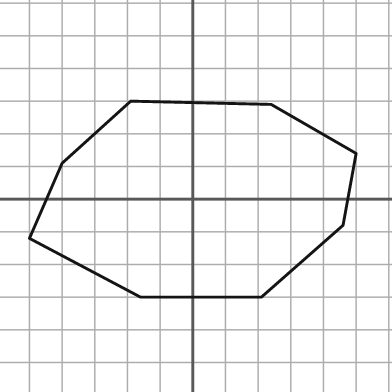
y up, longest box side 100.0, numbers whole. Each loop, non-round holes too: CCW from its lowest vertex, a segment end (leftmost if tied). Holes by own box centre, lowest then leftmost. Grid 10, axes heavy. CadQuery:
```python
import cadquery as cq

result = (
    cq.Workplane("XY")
    .moveTo(-16.0, -30.0)
    .lineTo(21.0, -30.0)
    .lineTo(46.0, -8.0)
    .lineTo(50.0, 14.0)
    .lineTo(24.0, 29.0)
    .lineTo(-19.0, 30.0)
    .lineTo(-40.0, 11.0)
    .lineTo(-50.0, -12.0)
    .close()
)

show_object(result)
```